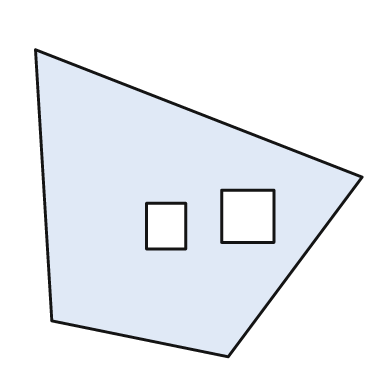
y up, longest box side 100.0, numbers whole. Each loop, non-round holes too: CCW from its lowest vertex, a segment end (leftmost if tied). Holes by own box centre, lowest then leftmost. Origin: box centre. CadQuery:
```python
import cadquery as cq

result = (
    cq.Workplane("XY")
    .moveTo(9.0, -47.0)
    .lineTo(50.0, 8.0)
    .lineTo(-50.0, 47.0)
    .lineTo(-45.0, -36.0)
    .close()
    .moveTo(-16.0, -14.0)
    .lineTo(-4.0, -14.0)
    .lineTo(-4.0, 0.0)
    .lineTo(-16.0, 0.0)
    .close()
    .moveTo(7.0, -12.0)
    .lineTo(23.0, -12.0)
    .lineTo(23.0, 4.0)
    .lineTo(7.0, 4.0)
    .close()
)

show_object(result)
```